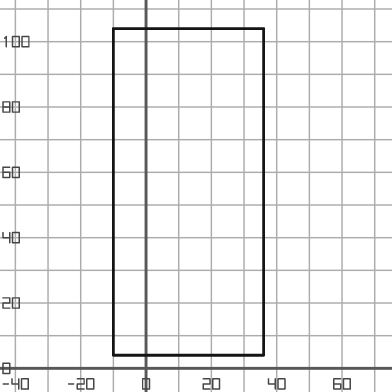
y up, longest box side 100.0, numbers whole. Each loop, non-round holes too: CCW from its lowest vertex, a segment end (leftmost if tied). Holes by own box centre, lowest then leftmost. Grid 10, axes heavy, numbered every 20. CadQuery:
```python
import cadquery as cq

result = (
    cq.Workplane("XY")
    .moveTo(-10.0, 4.0)
    .lineTo(36.0, 4.0)
    .lineTo(36.0, 104.0)
    .lineTo(-10.0, 104.0)
    .close()
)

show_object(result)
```